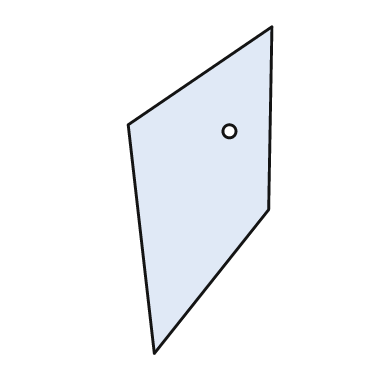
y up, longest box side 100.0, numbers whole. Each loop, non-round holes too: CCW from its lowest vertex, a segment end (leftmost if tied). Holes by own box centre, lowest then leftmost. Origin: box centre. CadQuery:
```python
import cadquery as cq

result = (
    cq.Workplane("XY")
    .moveTo(-14.0, -50.0)
    .lineTo(21.0, -6.0)
    .lineTo(22.0, 50.0)
    .lineTo(-22.0, 20.0)
    .close()
    .moveTo(9.0, 18.0)
    .circle(2.0)
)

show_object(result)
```